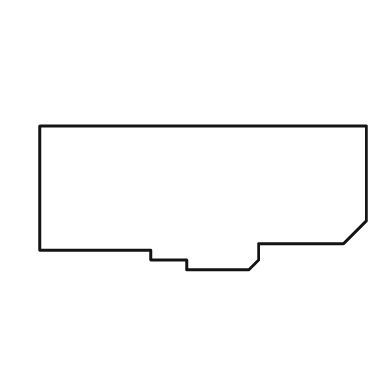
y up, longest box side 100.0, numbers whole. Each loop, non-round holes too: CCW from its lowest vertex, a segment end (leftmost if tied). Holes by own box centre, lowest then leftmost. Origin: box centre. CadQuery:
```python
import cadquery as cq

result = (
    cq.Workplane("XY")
    .moveTo(-5.0, -22.0)
    .lineTo(14.0, -22.0)
    .lineTo(17.0, -19.0)
    .lineTo(17.0, -14.0)
    .lineTo(43.0, -14.0)
    .lineTo(50.0, -7.0)
    .lineTo(50.0, 22.0)
    .lineTo(-50.0, 22.0)
    .lineTo(-50.0, -16.0)
    .lineTo(-16.0, -16.0)
    .lineTo(-16.0, -19.0)
    .lineTo(-5.0, -19.0)
    .close()
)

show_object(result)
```